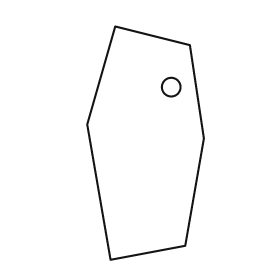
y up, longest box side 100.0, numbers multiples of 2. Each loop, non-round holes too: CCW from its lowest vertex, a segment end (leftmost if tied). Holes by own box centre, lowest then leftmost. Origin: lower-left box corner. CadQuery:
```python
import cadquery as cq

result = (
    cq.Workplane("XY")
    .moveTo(10.0, 0.0)
    .lineTo(42.0, 6.0)
    .lineTo(50.0, 52.0)
    .lineTo(44.0, 92.0)
    .lineTo(12.0, 100.0)
    .lineTo(0.0, 58.0)
    .close()
    .moveTo(36.0, 74.0)
    .circle(4.0)
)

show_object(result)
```